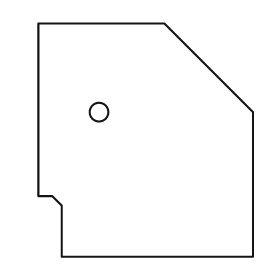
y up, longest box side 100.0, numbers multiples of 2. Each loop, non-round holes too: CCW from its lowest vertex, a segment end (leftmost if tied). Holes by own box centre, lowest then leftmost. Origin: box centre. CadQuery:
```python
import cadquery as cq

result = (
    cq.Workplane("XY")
    .moveTo(-36.0, -50.0)
    .lineTo(46.0, -50.0)
    .lineTo(46.0, 12.0)
    .lineTo(8.0, 50.0)
    .lineTo(-46.0, 50.0)
    .lineTo(-46.0, -24.0)
    .lineTo(-40.0, -24.0)
    .lineTo(-36.0, -28.0)
    .close()
    .moveTo(-20.0, 12.0)
    .circle(4.0)
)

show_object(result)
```